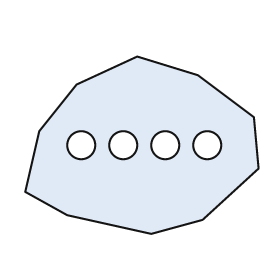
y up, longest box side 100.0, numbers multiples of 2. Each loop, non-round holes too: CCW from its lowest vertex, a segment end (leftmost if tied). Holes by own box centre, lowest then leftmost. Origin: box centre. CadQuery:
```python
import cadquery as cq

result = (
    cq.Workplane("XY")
    .moveTo(4.0, -38.0)
    .lineTo(26.0, -32.0)
    .lineTo(50.0, -10.0)
    .lineTo(48.0, 12.0)
    .lineTo(24.0, 30.0)
    .lineTo(-2.0, 38.0)
    .lineTo(-28.0, 26.0)
    .lineTo(-44.0, 6.0)
    .lineTo(-50.0, -20.0)
    .lineTo(-32.0, -30.0)
    .close()
    .moveTo(-26.0, 0.0)
    .circle(6.0)
    .moveTo(-8.0, 0.0)
    .circle(6.0)
    .moveTo(10.0, 0.0)
    .circle(6.0)
    .moveTo(28.0, 0.0)
    .circle(6.0)
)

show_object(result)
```